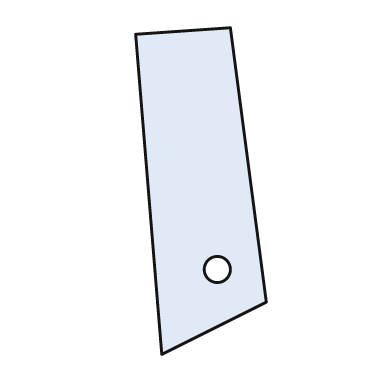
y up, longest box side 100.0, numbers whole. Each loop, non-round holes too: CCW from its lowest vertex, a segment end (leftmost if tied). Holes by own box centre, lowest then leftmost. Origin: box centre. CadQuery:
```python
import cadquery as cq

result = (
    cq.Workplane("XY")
    .moveTo(-12.0, -50.0)
    .lineTo(20.0, -34.0)
    .lineTo(9.0, 50.0)
    .lineTo(-20.0, 48.0)
    .close()
    .moveTo(5.0, -24.0)
    .circle(4.0)
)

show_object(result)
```